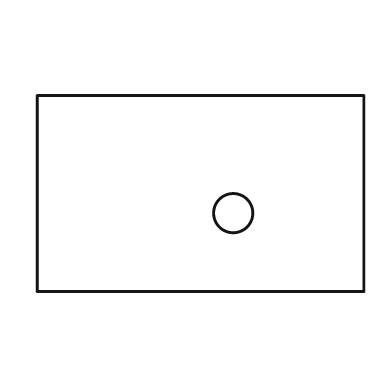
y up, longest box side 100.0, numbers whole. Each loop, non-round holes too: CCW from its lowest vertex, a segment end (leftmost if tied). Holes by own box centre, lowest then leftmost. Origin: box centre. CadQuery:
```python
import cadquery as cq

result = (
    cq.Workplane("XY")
    .moveTo(-50.0, -30.0)
    .lineTo(50.0, -30.0)
    .lineTo(50.0, 30.0)
    .lineTo(-50.0, 30.0)
    .close()
    .moveTo(10.0, -6.0)
    .circle(6.0)
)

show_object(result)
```